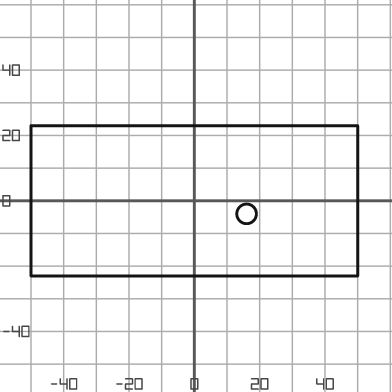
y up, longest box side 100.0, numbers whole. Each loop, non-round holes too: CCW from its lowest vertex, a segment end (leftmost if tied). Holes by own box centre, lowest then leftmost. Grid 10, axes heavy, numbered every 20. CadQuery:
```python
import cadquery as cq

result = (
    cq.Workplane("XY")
    .moveTo(-50.0, -23.0)
    .lineTo(50.0, -23.0)
    .lineTo(50.0, 23.0)
    .lineTo(-50.0, 23.0)
    .close()
    .moveTo(16.0, -4.0)
    .circle(3.0)
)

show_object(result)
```